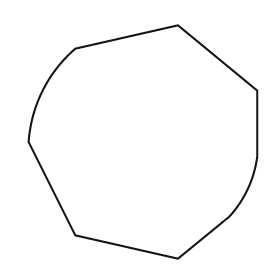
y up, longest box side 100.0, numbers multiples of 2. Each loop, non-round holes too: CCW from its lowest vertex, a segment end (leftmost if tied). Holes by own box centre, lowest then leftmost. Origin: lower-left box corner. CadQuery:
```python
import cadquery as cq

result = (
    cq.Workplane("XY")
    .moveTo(64.0, 0.0)
    .lineTo(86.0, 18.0)
    .threePointArc((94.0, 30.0), (98.0, 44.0))
    .lineTo(98.0, 72.0)
    .lineTo(64.0, 100.0)
    .lineTo(20.0, 90.0)
    .threePointArc((6.0, 72.0), (0.0, 50.0))
    .lineTo(20.0, 10.0)
    .close()
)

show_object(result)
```